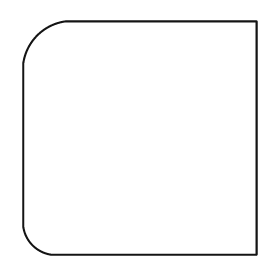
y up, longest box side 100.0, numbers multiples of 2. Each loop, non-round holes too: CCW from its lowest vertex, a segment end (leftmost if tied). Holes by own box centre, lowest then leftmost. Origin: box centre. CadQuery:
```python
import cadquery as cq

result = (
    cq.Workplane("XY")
    .moveTo(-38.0, -50.0)
    .lineTo(50.0, -50.0)
    .lineTo(50.0, 50.0)
    .lineTo(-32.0, 50.0)
    .threePointArc((-44.0, 44.0), (-50.0, 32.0))
    .lineTo(-50.0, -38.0)
    .threePointArc((-46.0, -46.0), (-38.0, -50.0))
    .close()
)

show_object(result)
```